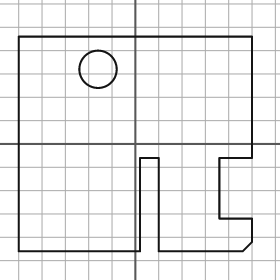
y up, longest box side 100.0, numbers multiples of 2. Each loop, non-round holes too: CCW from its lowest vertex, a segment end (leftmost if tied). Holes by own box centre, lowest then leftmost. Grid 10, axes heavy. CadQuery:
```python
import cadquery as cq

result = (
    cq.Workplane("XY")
    .moveTo(-50.0, -46.0)
    .lineTo(2.0, -46.0)
    .lineTo(2.0, -6.0)
    .lineTo(10.0, -6.0)
    .lineTo(10.0, -46.0)
    .lineTo(46.0, -46.0)
    .lineTo(50.0, -42.0)
    .lineTo(50.0, -32.0)
    .lineTo(36.0, -32.0)
    .lineTo(36.0, -6.0)
    .lineTo(50.0, -6.0)
    .lineTo(50.0, 46.0)
    .lineTo(-50.0, 46.0)
    .close()
    .moveTo(-16.0, 32.0)
    .circle(8.0)
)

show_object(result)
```